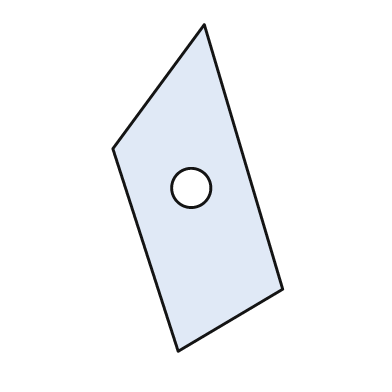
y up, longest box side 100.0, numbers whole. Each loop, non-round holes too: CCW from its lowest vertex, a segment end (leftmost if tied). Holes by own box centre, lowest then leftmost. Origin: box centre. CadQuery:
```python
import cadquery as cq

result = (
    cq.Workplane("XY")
    .moveTo(-6.0, -50.0)
    .lineTo(26.0, -31.0)
    .lineTo(2.0, 50.0)
    .lineTo(-26.0, 12.0)
    .close()
    .moveTo(-2.0, 0.0)
    .circle(6.0)
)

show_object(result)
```